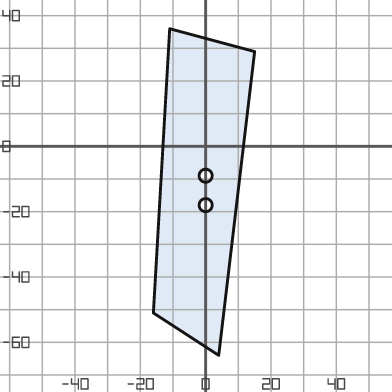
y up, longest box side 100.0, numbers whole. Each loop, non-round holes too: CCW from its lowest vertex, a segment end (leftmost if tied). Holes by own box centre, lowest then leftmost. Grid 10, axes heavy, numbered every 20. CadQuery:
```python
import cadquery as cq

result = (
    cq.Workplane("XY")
    .moveTo(4.0, -64.0)
    .lineTo(15.0, 29.0)
    .lineTo(-11.0, 36.0)
    .lineTo(-16.0, -51.0)
    .close()
    .moveTo(0.0, -18.0)
    .circle(2.0)
    .moveTo(0.0, -9.0)
    .circle(2.0)
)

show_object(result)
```